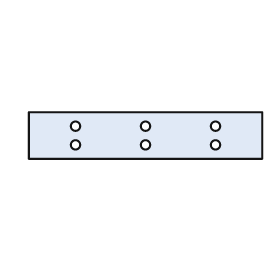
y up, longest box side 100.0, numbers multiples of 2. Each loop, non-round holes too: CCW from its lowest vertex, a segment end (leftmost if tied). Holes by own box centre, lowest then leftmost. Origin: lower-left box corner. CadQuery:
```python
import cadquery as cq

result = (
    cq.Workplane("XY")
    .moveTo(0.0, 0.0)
    .lineTo(100.0, 0.0)
    .lineTo(100.0, 20.0)
    .lineTo(0.0, 20.0)
    .close()
    .moveTo(20.0, 6.0)
    .circle(2.0)
    .moveTo(50.0, 6.0)
    .circle(2.0)
    .moveTo(80.0, 6.0)
    .circle(2.0)
    .moveTo(20.0, 14.0)
    .circle(2.0)
    .moveTo(50.0, 14.0)
    .circle(2.0)
    .moveTo(80.0, 14.0)
    .circle(2.0)
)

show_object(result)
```